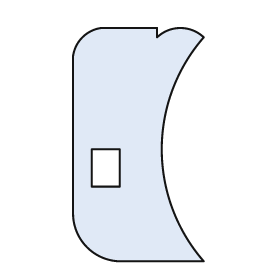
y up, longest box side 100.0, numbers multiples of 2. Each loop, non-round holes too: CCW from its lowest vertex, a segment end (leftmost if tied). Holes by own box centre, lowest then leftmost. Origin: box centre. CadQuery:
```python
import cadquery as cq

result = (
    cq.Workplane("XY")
    .moveTo(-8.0, -50.0)
    .lineTo(28.0, -50.0)
    .threePointArc((10.0, -2.0), (28.0, 46.0))
    .threePointArc((18.0, 50.0), (8.0, 46.0))
    .lineTo(8.0, 50.0)
    .lineTo(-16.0, 50.0)
    .threePointArc((-24.0, 46.0), (-28.0, 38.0))
    .lineTo(-28.0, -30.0)
    .threePointArc((-22.0, -44.0), (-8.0, -50.0))
    .close()
    .moveTo(-20.0, -18.0)
    .lineTo(-8.0, -18.0)
    .lineTo(-8.0, -2.0)
    .lineTo(-20.0, -2.0)
    .close()
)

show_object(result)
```